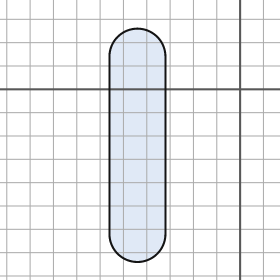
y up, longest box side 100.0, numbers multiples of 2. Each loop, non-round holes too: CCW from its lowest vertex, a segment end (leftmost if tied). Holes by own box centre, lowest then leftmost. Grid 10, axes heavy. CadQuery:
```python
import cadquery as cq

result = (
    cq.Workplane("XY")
    .moveTo(-56.0, -62.0)
    .threePointArc((-44.0, -74.0), (-32.0, -62.0))
    .lineTo(-32.0, 14.0)
    .threePointArc((-44.0, 26.0), (-56.0, 14.0))
    .close()
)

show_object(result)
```